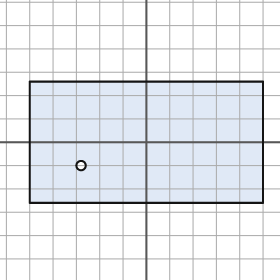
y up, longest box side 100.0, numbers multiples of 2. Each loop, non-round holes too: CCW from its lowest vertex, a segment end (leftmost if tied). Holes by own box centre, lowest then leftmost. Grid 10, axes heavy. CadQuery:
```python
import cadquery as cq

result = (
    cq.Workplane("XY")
    .moveTo(-50.0, -26.0)
    .lineTo(50.0, -26.0)
    .lineTo(50.0, 26.0)
    .lineTo(-50.0, 26.0)
    .close()
    .moveTo(-28.0, -10.0)
    .circle(2.0)
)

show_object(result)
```